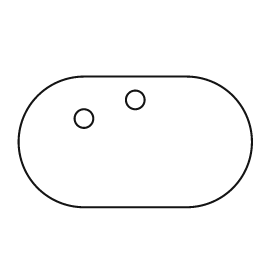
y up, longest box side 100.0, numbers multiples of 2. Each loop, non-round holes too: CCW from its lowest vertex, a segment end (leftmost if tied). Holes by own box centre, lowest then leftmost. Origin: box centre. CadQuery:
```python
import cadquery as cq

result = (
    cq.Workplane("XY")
    .moveTo(-22.0, -28.0)
    .lineTo(22.0, -28.0)
    .threePointArc((50.0, 0.0), (22.0, 28.0))
    .lineTo(-22.0, 28.0)
    .threePointArc((-50.0, 0.0), (-22.0, -28.0))
    .close()
    .moveTo(-22.0, 10.0)
    .circle(4.0)
    .moveTo(0.0, 18.0)
    .circle(4.0)
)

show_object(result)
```